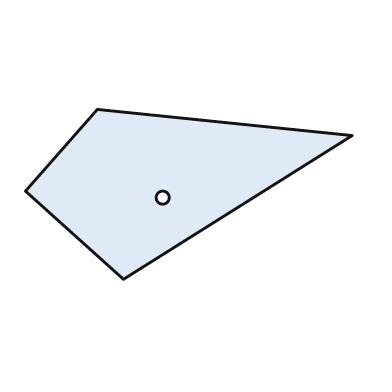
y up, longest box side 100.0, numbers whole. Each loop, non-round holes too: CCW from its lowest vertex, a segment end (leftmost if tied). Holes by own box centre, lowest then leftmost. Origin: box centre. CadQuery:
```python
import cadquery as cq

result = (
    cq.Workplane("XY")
    .moveTo(-20.0, -26.0)
    .lineTo(50.0, 18.0)
    .lineTo(-28.0, 26.0)
    .lineTo(-50.0, 1.0)
    .close()
    .moveTo(-8.0, -1.0)
    .circle(2.0)
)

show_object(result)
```